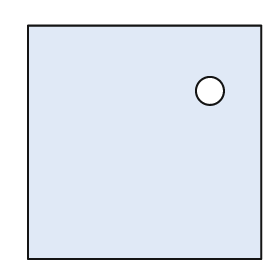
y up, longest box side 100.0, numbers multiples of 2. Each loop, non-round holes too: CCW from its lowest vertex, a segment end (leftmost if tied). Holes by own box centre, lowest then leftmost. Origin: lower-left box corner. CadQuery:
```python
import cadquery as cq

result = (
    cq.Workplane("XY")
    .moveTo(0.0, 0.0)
    .lineTo(100.0, 0.0)
    .lineTo(100.0, 100.0)
    .lineTo(0.0, 100.0)
    .close()
    .moveTo(78.0, 72.0)
    .circle(6.0)
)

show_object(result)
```